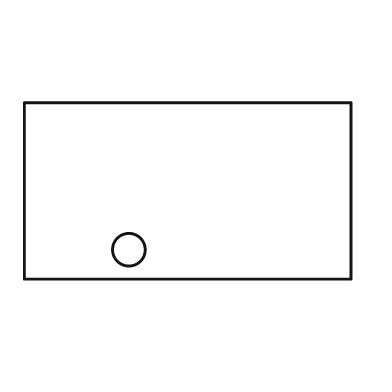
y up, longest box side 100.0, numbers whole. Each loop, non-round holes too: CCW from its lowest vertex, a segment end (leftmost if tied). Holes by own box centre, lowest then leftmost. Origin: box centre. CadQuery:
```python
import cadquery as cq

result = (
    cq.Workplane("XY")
    .moveTo(-50.0, -27.0)
    .lineTo(50.0, -27.0)
    .lineTo(50.0, 27.0)
    .lineTo(-50.0, 27.0)
    .close()
    .moveTo(-18.0, -18.0)
    .circle(5.0)
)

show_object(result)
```